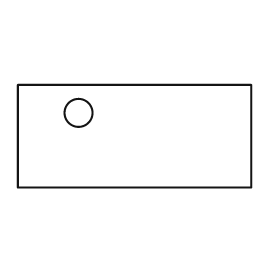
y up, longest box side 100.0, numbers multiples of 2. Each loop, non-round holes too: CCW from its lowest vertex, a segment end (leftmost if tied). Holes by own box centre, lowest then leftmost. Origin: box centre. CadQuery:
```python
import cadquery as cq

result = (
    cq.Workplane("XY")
    .moveTo(-50.0, -22.0)
    .lineTo(50.0, -22.0)
    .lineTo(50.0, 22.0)
    .lineTo(-50.0, 22.0)
    .close()
    .moveTo(-24.0, 10.0)
    .circle(6.0)
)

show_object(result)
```